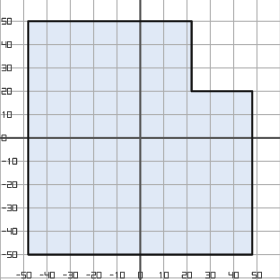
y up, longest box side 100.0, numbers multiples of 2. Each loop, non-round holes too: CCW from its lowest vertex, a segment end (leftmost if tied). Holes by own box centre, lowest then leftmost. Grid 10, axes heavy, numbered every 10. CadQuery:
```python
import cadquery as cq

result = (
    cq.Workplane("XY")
    .moveTo(-48.0, -50.0)
    .lineTo(48.0, -50.0)
    .lineTo(48.0, 20.0)
    .lineTo(22.0, 20.0)
    .lineTo(22.0, 50.0)
    .lineTo(-48.0, 50.0)
    .close()
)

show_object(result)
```